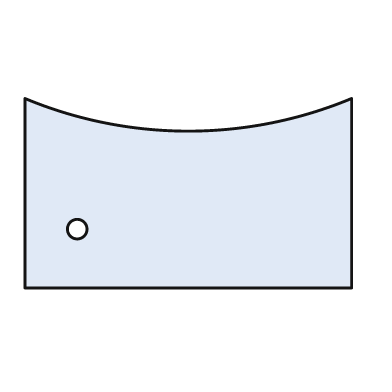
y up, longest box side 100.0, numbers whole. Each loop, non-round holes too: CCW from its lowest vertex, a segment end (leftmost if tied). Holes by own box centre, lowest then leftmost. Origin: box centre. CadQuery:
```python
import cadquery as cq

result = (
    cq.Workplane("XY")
    .moveTo(-50.0, -29.0)
    .lineTo(50.0, -29.0)
    .lineTo(50.0, 29.0)
    .threePointArc((0.0, 19.0), (-50.0, 29.0))
    .close()
    .moveTo(-34.0, -11.0)
    .circle(3.0)
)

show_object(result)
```